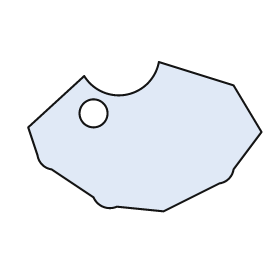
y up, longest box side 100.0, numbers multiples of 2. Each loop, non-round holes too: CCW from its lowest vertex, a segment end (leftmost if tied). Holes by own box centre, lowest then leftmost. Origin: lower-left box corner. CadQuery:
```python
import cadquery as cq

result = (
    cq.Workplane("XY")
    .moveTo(58.0, 0.0)
    .lineTo(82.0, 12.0)
    .threePointArc((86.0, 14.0), (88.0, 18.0))
    .lineTo(100.0, 34.0)
    .lineTo(88.0, 54.0)
    .lineTo(56.0, 64.0)
    .threePointArc((42.0, 50.0), (24.0, 58.0))
    .lineTo(0.0, 36.0)
    .lineTo(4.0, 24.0)
    .threePointArc((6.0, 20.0), (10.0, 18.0))
    .lineTo(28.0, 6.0)
    .threePointArc((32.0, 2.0), (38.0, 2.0))
    .close()
    .moveTo(28.0, 42.0)
    .circle(6.0)
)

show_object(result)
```